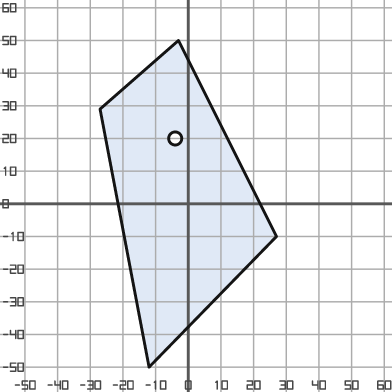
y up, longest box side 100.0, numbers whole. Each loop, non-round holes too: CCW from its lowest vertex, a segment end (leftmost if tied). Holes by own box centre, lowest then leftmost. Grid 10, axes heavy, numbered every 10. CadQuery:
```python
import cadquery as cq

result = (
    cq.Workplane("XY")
    .moveTo(-12.0, -50.0)
    .lineTo(27.0, -10.0)
    .lineTo(-3.0, 50.0)
    .lineTo(-27.0, 29.0)
    .close()
    .moveTo(-4.0, 20.0)
    .circle(2.0)
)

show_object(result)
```